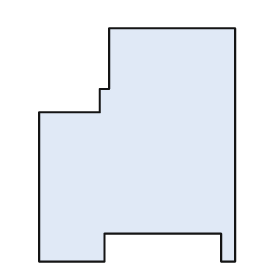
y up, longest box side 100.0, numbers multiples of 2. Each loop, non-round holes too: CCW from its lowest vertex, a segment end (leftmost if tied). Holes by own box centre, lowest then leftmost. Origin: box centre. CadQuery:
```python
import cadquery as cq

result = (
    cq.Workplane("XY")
    .moveTo(-42.0, -50.0)
    .lineTo(-14.0, -50.0)
    .lineTo(-14.0, -38.0)
    .lineTo(36.0, -38.0)
    .lineTo(36.0, -50.0)
    .lineTo(42.0, -50.0)
    .lineTo(42.0, 50.0)
    .lineTo(-12.0, 50.0)
    .lineTo(-12.0, 24.0)
    .lineTo(-16.0, 24.0)
    .lineTo(-16.0, 14.0)
    .lineTo(-42.0, 14.0)
    .close()
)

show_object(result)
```